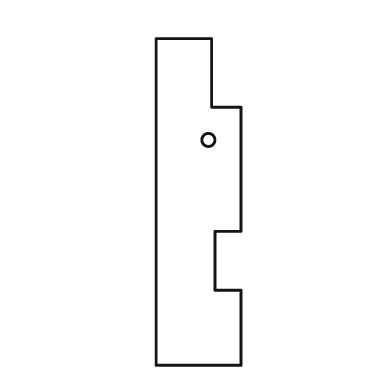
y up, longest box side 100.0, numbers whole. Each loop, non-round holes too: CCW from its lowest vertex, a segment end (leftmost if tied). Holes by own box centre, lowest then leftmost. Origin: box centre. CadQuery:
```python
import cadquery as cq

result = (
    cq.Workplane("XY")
    .moveTo(-13.0, -50.0)
    .lineTo(13.0, -50.0)
    .lineTo(13.0, -27.0)
    .lineTo(5.0, -27.0)
    .lineTo(5.0, -9.0)
    .lineTo(13.0, -9.0)
    .lineTo(13.0, 29.0)
    .lineTo(4.0, 29.0)
    .lineTo(4.0, 50.0)
    .lineTo(-13.0, 50.0)
    .close()
    .moveTo(3.0, 19.0)
    .circle(2.0)
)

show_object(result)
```